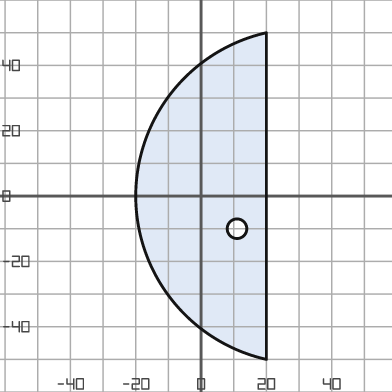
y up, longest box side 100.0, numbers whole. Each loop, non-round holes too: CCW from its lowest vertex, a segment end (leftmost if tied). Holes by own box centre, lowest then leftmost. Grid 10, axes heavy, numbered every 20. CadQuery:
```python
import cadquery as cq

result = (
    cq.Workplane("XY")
    .moveTo(20.0, -50.0)
    .lineTo(20.0, 50.0)
    .threePointArc((-20.0, 0.0), (20.0, -50.0))
    .close()
    .moveTo(11.0, -10.0)
    .circle(3.0)
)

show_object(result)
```